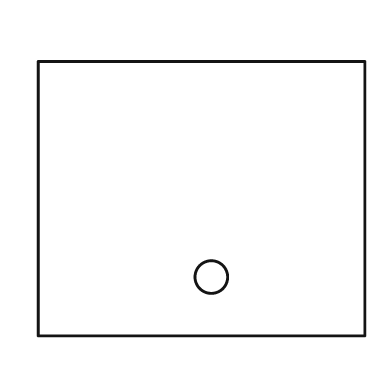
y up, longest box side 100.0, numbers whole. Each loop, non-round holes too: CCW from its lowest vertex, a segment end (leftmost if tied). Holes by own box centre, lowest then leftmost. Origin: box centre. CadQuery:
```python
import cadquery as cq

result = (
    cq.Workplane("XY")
    .moveTo(-50.0, -42.0)
    .lineTo(50.0, -42.0)
    .lineTo(50.0, 42.0)
    .lineTo(-50.0, 42.0)
    .close()
    .moveTo(3.0, -24.0)
    .circle(5.0)
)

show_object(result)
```